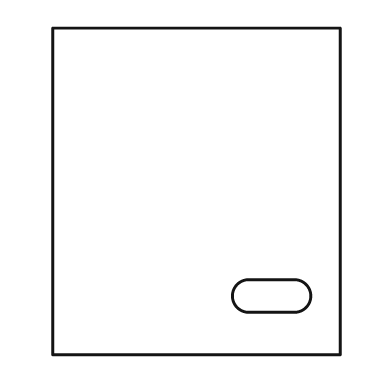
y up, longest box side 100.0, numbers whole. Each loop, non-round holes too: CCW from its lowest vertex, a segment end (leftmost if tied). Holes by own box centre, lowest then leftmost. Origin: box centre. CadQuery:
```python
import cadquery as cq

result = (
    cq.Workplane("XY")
    .moveTo(-44.0, -50.0)
    .lineTo(44.0, -50.0)
    .lineTo(44.0, 50.0)
    .lineTo(-44.0, 50.0)
    .close()
    .moveTo(16.0, -37.0)
    .lineTo(30.0, -37.0)
    .threePointArc((35.0, -32.0), (30.0, -27.0))
    .lineTo(16.0, -27.0)
    .threePointArc((11.0, -32.0), (16.0, -37.0))
    .close()
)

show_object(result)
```